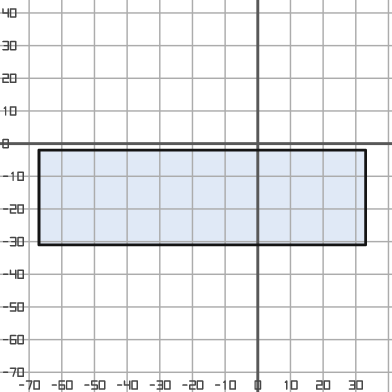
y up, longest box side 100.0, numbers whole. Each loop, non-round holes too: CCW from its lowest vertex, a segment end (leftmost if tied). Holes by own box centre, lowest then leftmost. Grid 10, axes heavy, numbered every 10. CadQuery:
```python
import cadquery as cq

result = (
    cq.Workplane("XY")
    .moveTo(-67.0, -31.0)
    .lineTo(33.0, -31.0)
    .lineTo(33.0, -2.0)
    .lineTo(-67.0, -2.0)
    .close()
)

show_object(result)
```